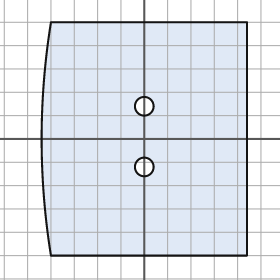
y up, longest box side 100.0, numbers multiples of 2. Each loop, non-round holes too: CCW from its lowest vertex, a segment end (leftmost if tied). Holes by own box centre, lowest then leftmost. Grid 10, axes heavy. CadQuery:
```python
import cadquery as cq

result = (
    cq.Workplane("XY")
    .moveTo(-40.0, -50.0)
    .lineTo(44.0, -50.0)
    .lineTo(44.0, 50.0)
    .lineTo(-40.0, 50.0)
    .threePointArc((-44.0, 0.0), (-40.0, -50.0))
    .close()
    .moveTo(0.0, -12.0)
    .circle(4.0)
    .moveTo(0.0, 14.0)
    .circle(4.0)
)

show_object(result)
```